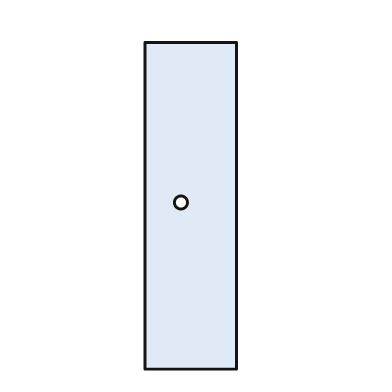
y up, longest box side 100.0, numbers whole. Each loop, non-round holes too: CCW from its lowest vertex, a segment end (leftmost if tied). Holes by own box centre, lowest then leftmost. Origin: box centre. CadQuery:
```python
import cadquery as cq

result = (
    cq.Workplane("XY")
    .moveTo(-14.0, -50.0)
    .lineTo(14.0, -50.0)
    .lineTo(14.0, 50.0)
    .lineTo(-14.0, 50.0)
    .close()
    .moveTo(-3.0, 1.0)
    .circle(2.0)
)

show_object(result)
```